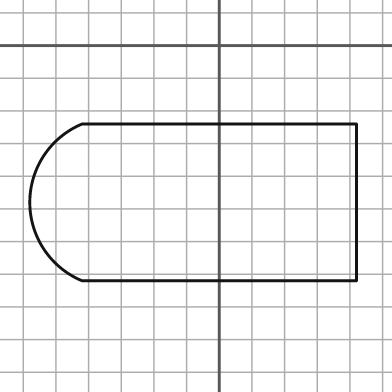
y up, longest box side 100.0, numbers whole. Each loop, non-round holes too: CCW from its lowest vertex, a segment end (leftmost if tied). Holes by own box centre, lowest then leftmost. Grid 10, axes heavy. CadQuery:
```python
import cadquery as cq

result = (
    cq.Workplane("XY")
    .moveTo(-42.0, -72.0)
    .lineTo(42.0, -72.0)
    .lineTo(42.0, -24.0)
    .lineTo(-42.0, -24.0)
    .threePointArc((-58.0, -48.0), (-42.0, -72.0))
    .close()
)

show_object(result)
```